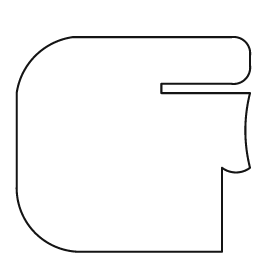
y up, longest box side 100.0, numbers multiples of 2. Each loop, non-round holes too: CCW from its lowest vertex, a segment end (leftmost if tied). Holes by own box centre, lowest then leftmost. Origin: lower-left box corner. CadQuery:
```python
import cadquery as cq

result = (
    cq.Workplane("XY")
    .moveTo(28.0, 0.0)
    .lineTo(88.0, 0.0)
    .lineTo(88.0, 36.0)
    .threePointArc((94.0, 34.0), (100.0, 36.0))
    .threePointArc((98.0, 52.0), (100.0, 68.0))
    .lineTo(62.0, 68.0)
    .lineTo(62.0, 72.0)
    .lineTo(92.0, 72.0)
    .threePointArc((98.0, 74.0), (100.0, 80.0))
    .lineTo(100.0, 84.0)
    .threePointArc((98.0, 90.0), (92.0, 92.0))
    .lineTo(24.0, 92.0)
    .threePointArc((8.0, 84.0), (0.0, 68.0))
    .lineTo(0.0, 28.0)
    .threePointArc((8.0, 8.0), (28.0, 0.0))
    .close()
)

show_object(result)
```